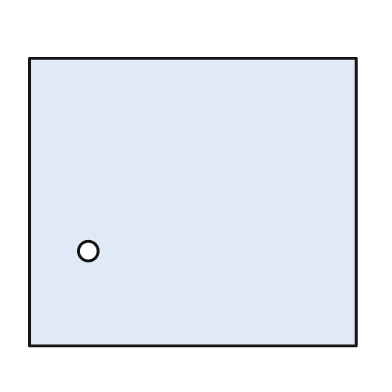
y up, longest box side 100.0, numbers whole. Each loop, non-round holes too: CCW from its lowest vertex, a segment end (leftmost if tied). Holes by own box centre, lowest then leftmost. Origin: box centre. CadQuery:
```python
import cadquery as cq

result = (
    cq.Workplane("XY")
    .moveTo(-50.0, -44.0)
    .lineTo(50.0, -44.0)
    .lineTo(50.0, 44.0)
    .lineTo(-50.0, 44.0)
    .close()
    .moveTo(-32.0, -15.0)
    .circle(3.0)
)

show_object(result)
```